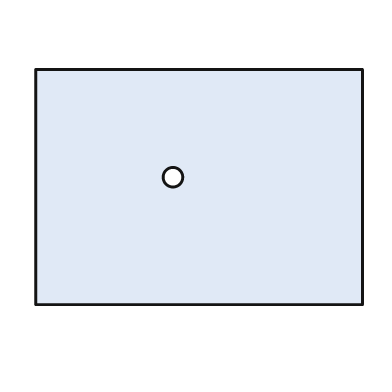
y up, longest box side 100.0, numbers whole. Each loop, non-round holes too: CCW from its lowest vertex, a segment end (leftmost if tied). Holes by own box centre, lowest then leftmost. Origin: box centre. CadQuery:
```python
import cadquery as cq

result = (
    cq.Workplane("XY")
    .moveTo(-50.0, -36.0)
    .lineTo(50.0, -36.0)
    .lineTo(50.0, 36.0)
    .lineTo(-50.0, 36.0)
    .close()
    .moveTo(-8.0, 3.0)
    .circle(3.0)
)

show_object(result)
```